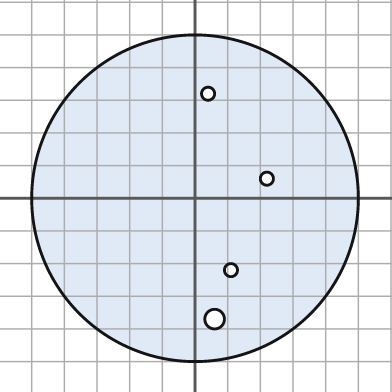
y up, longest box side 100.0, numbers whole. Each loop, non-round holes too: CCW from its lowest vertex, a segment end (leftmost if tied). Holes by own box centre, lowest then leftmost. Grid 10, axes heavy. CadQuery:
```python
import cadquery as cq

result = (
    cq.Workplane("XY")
    .moveTo(0.0, 0.0)
    .circle(50.0)
    .moveTo(6.0, -37.0)
    .circle(3.0)
    .moveTo(11.0, -22.0)
    .circle(2.0)
    .moveTo(22.0, 6.0)
    .circle(2.0)
    .moveTo(4.0, 32.0)
    .circle(2.0)
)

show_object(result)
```